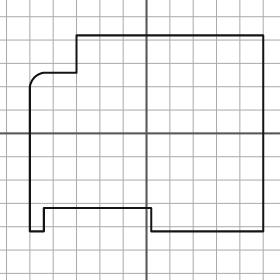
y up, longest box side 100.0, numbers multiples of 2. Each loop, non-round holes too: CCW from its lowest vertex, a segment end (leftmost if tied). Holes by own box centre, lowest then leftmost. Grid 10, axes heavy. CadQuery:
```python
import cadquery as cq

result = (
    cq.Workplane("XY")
    .moveTo(-50.0, -42.0)
    .lineTo(-44.0, -42.0)
    .lineTo(-44.0, -32.0)
    .lineTo(2.0, -32.0)
    .lineTo(2.0, -42.0)
    .lineTo(50.0, -42.0)
    .lineTo(50.0, 42.0)
    .lineTo(-30.0, 42.0)
    .lineTo(-30.0, 26.0)
    .lineTo(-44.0, 26.0)
    .threePointArc((-48.0, 24.0), (-50.0, 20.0))
    .close()
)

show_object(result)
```